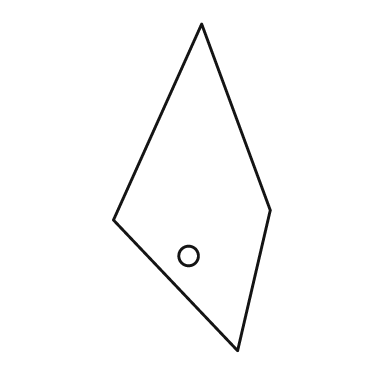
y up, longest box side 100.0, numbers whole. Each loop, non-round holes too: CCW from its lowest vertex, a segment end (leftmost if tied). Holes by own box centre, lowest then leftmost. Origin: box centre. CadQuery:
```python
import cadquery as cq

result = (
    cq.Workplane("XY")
    .moveTo(14.0, -50.0)
    .lineTo(24.0, -7.0)
    .lineTo(3.0, 50.0)
    .lineTo(-24.0, -10.0)
    .close()
    .moveTo(-1.0, -21.0)
    .circle(3.0)
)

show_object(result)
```